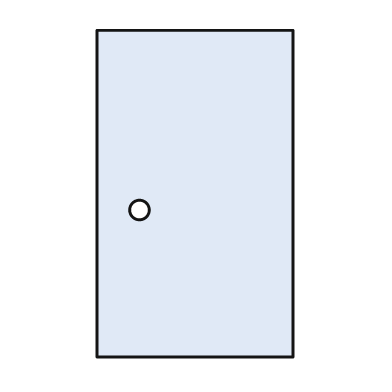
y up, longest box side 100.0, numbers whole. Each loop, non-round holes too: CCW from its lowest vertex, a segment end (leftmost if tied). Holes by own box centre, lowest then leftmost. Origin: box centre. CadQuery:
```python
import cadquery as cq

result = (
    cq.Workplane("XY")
    .moveTo(-30.0, -50.0)
    .lineTo(30.0, -50.0)
    .lineTo(30.0, 50.0)
    .lineTo(-30.0, 50.0)
    .close()
    .moveTo(-17.0, -5.0)
    .circle(3.0)
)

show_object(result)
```